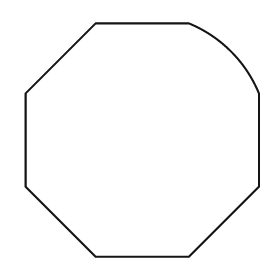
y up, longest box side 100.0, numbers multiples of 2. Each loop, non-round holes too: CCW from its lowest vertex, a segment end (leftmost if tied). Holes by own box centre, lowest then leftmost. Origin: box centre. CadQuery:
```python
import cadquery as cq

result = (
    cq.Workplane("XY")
    .moveTo(-20.0, -50.0)
    .lineTo(20.0, -50.0)
    .lineTo(50.0, -20.0)
    .lineTo(50.0, 20.0)
    .threePointArc((38.0, 38.0), (20.0, 50.0))
    .lineTo(-20.0, 50.0)
    .lineTo(-50.0, 20.0)
    .lineTo(-50.0, -20.0)
    .close()
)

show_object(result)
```